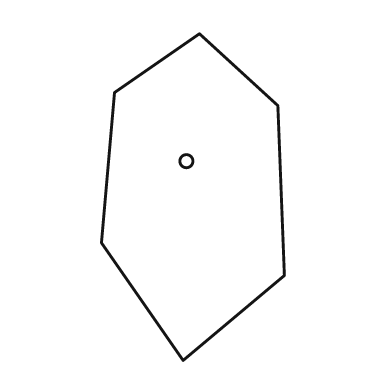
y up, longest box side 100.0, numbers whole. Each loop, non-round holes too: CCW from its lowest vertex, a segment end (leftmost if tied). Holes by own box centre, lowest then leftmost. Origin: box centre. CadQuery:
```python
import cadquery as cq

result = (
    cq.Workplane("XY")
    .moveTo(-3.0, -50.0)
    .lineTo(28.0, -24.0)
    .lineTo(26.0, 28.0)
    .lineTo(2.0, 50.0)
    .lineTo(-24.0, 32.0)
    .lineTo(-28.0, -14.0)
    .close()
    .moveTo(-2.0, 11.0)
    .circle(2.0)
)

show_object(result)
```